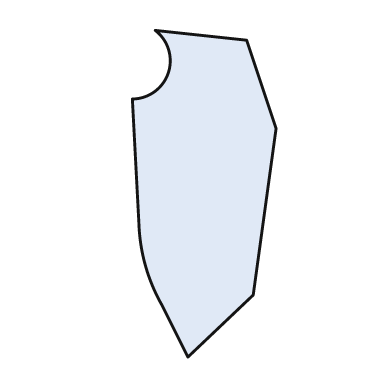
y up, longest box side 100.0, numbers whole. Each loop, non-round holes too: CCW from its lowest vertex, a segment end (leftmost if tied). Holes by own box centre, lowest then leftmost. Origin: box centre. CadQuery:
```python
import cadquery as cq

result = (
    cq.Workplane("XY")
    .moveTo(-5.0, -50.0)
    .lineTo(15.0, -31.0)
    .lineTo(22.0, 20.0)
    .lineTo(13.0, 47.0)
    .lineTo(-15.0, 50.0)
    .threePointArc((-11.0, 37.0), (-22.0, 29.0))
    .lineTo(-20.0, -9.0)
    .threePointArc((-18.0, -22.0), (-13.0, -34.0))
    .close()
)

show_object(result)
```